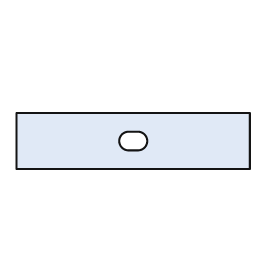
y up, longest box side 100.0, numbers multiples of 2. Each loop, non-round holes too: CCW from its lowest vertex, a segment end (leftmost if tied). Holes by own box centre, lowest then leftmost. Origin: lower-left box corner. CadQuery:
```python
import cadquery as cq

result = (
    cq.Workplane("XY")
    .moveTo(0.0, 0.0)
    .lineTo(100.0, 0.0)
    .lineTo(100.0, 24.0)
    .lineTo(0.0, 24.0)
    .close()
    .moveTo(48.0, 8.0)
    .lineTo(52.0, 8.0)
    .threePointArc((56.0, 12.0), (52.0, 16.0))
    .lineTo(48.0, 16.0)
    .threePointArc((44.0, 12.0), (48.0, 8.0))
    .close()
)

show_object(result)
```